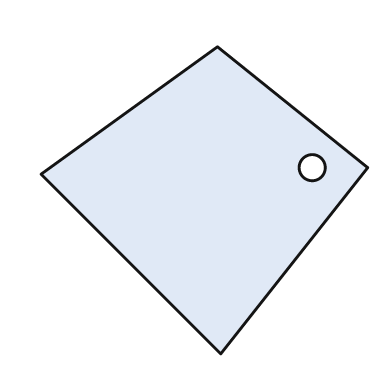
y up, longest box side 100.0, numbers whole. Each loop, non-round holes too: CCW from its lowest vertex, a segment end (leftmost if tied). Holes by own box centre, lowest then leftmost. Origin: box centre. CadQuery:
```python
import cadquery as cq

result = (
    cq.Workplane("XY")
    .moveTo(5.0, -47.0)
    .lineTo(50.0, 10.0)
    .lineTo(4.0, 47.0)
    .lineTo(-50.0, 8.0)
    .close()
    .moveTo(33.0, 10.0)
    .circle(4.0)
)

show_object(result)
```